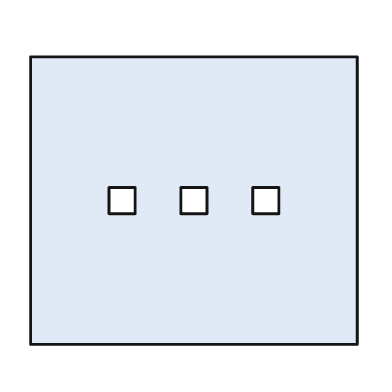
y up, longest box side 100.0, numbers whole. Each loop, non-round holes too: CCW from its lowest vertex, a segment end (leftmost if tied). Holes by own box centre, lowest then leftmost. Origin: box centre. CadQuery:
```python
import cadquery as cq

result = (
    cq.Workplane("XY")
    .moveTo(-50.0, -44.0)
    .lineTo(50.0, -44.0)
    .lineTo(50.0, 44.0)
    .lineTo(-50.0, 44.0)
    .close()
    .moveTo(-26.0, -4.0)
    .lineTo(-18.0, -4.0)
    .lineTo(-18.0, 4.0)
    .lineTo(-26.0, 4.0)
    .close()
    .moveTo(-4.0, -4.0)
    .lineTo(4.0, -4.0)
    .lineTo(4.0, 4.0)
    .lineTo(-4.0, 4.0)
    .close()
    .moveTo(18.0, -4.0)
    .lineTo(26.0, -4.0)
    .lineTo(26.0, 4.0)
    .lineTo(18.0, 4.0)
    .close()
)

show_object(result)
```